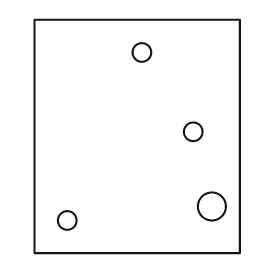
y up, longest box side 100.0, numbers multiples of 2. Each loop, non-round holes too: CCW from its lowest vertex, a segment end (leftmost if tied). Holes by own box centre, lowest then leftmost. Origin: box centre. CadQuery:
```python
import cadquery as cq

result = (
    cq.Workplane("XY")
    .moveTo(-44.0, -50.0)
    .lineTo(44.0, -50.0)
    .lineTo(44.0, 50.0)
    .lineTo(-44.0, 50.0)
    .close()
    .moveTo(-30.0, -36.0)
    .circle(4.0)
    .moveTo(32.0, -30.0)
    .circle(6.0)
    .moveTo(24.0, 2.0)
    .circle(4.0)
    .moveTo(2.0, 36.0)
    .circle(4.0)
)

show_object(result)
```